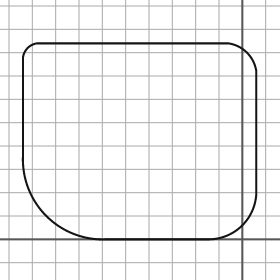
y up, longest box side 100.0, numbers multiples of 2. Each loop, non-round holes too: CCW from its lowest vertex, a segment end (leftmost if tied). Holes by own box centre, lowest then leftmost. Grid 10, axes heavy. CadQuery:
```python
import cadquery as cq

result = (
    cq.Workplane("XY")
    .moveTo(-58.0, 0.0)
    .lineTo(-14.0, 0.0)
    .threePointArc((0.0, 6.0), (6.0, 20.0))
    .lineTo(6.0, 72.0)
    .threePointArc((2.0, 80.0), (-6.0, 84.0))
    .lineTo(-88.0, 84.0)
    .threePointArc((-92.0, 82.0), (-94.0, 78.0))
    .lineTo(-94.0, 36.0)
    .threePointArc((-84.0, 10.0), (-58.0, 0.0))
    .close()
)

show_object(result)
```